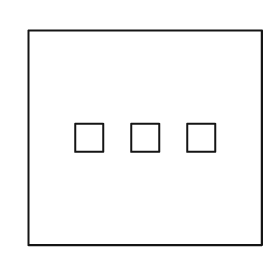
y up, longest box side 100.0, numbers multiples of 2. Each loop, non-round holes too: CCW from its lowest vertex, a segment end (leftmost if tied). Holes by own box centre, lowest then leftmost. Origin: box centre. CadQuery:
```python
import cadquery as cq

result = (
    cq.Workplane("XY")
    .moveTo(-50.0, -46.0)
    .lineTo(50.0, -46.0)
    .lineTo(50.0, 46.0)
    .lineTo(-50.0, 46.0)
    .close()
    .moveTo(-30.0, -6.0)
    .lineTo(-18.0, -6.0)
    .lineTo(-18.0, 6.0)
    .lineTo(-30.0, 6.0)
    .close()
    .moveTo(-6.0, -6.0)
    .lineTo(6.0, -6.0)
    .lineTo(6.0, 6.0)
    .lineTo(-6.0, 6.0)
    .close()
    .moveTo(18.0, -6.0)
    .lineTo(30.0, -6.0)
    .lineTo(30.0, 6.0)
    .lineTo(18.0, 6.0)
    .close()
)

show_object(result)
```